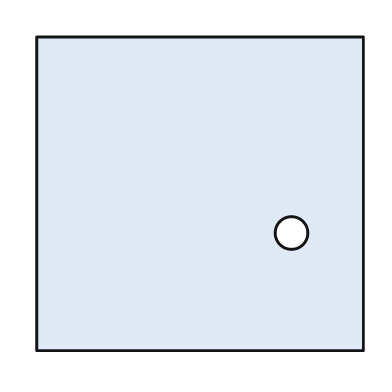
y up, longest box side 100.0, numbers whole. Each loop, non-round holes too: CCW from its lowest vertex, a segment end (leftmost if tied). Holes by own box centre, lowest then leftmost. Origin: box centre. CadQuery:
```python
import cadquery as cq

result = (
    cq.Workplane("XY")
    .moveTo(-50.0, -48.0)
    .lineTo(50.0, -48.0)
    .lineTo(50.0, 48.0)
    .lineTo(-50.0, 48.0)
    .close()
    .moveTo(28.0, -12.0)
    .circle(5.0)
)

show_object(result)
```